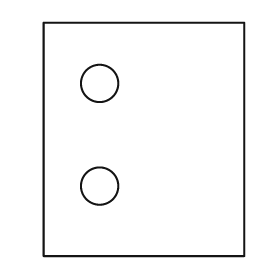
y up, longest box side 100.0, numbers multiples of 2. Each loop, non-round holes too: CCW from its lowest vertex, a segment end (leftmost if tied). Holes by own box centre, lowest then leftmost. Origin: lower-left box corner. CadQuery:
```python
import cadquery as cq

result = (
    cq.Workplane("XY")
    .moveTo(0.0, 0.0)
    .lineTo(86.0, 0.0)
    .lineTo(86.0, 100.0)
    .lineTo(0.0, 100.0)
    .close()
    .moveTo(24.0, 30.0)
    .circle(8.0)
    .moveTo(24.0, 74.0)
    .circle(8.0)
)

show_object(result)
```